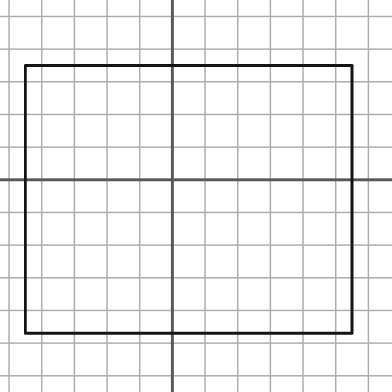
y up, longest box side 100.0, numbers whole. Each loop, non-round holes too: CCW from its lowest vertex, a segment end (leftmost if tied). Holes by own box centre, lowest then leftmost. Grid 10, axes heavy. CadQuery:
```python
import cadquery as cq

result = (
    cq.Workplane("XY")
    .moveTo(-45.0, -47.0)
    .lineTo(55.0, -47.0)
    .lineTo(55.0, 35.0)
    .lineTo(-45.0, 35.0)
    .close()
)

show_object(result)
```